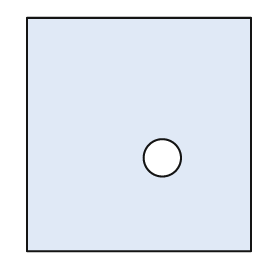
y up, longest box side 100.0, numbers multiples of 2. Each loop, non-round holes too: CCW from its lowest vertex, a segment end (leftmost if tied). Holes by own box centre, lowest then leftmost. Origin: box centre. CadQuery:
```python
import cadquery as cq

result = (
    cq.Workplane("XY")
    .moveTo(-48.0, -50.0)
    .lineTo(48.0, -50.0)
    .lineTo(48.0, 50.0)
    .lineTo(-48.0, 50.0)
    .close()
    .moveTo(10.0, -10.0)
    .circle(8.0)
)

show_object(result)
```